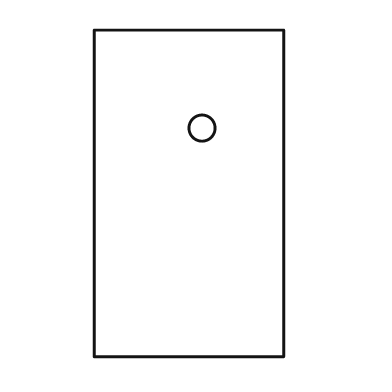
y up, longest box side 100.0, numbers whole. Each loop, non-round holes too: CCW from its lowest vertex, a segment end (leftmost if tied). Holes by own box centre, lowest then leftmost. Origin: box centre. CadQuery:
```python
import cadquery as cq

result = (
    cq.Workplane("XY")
    .moveTo(-29.0, -50.0)
    .lineTo(29.0, -50.0)
    .lineTo(29.0, 50.0)
    .lineTo(-29.0, 50.0)
    .close()
    .moveTo(4.0, 20.0)
    .circle(4.0)
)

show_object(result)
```